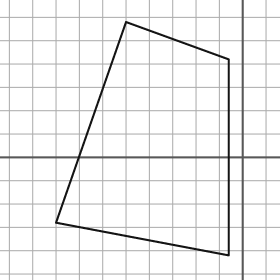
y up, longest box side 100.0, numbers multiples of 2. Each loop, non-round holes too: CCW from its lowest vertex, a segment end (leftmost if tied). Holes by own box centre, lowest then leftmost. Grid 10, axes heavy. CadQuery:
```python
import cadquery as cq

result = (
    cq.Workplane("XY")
    .moveTo(-6.0, -42.0)
    .lineTo(-6.0, 42.0)
    .lineTo(-50.0, 58.0)
    .lineTo(-80.0, -28.0)
    .close()
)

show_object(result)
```